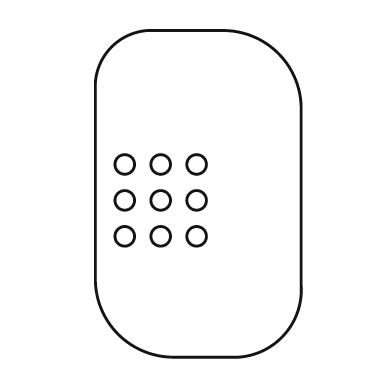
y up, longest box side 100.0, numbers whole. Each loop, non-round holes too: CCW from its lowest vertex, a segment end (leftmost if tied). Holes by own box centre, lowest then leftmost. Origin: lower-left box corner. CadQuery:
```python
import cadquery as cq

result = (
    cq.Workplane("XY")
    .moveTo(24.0, 0.0)
    .lineTo(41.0, 0.0)
    .threePointArc((57.0, 6.0), (63.0, 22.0))
    .lineTo(63.0, 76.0)
    .threePointArc((56.0, 93.0), (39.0, 100.0))
    .lineTo(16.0, 100.0)
    .threePointArc((5.0, 95.0), (0.0, 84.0))
    .lineTo(0.0, 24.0)
    .threePointArc((7.0, 7.0), (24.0, 0.0))
    .close()
    .moveTo(9.0, 37.0)
    .circle(3.0)
    .moveTo(20.0, 37.0)
    .circle(3.0)
    .moveTo(31.0, 37.0)
    .circle(3.0)
    .moveTo(9.0, 48.0)
    .circle(3.0)
    .moveTo(20.0, 48.0)
    .circle(3.0)
    .moveTo(31.0, 48.0)
    .circle(3.0)
    .moveTo(9.0, 59.0)
    .circle(3.0)
    .moveTo(20.0, 59.0)
    .circle(3.0)
    .moveTo(31.0, 59.0)
    .circle(3.0)
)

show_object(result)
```